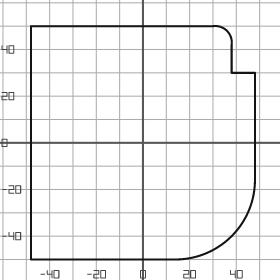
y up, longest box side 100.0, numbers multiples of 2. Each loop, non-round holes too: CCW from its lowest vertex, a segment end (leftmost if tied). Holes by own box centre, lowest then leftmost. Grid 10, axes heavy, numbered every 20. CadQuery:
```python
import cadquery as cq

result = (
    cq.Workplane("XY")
    .moveTo(-48.0, -50.0)
    .lineTo(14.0, -50.0)
    .threePointArc((38.0, -40.0), (48.0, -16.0))
    .lineTo(48.0, 30.0)
    .lineTo(38.0, 30.0)
    .lineTo(38.0, 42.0)
    .threePointArc((36.0, 48.0), (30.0, 50.0))
    .lineTo(-48.0, 50.0)
    .close()
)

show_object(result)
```